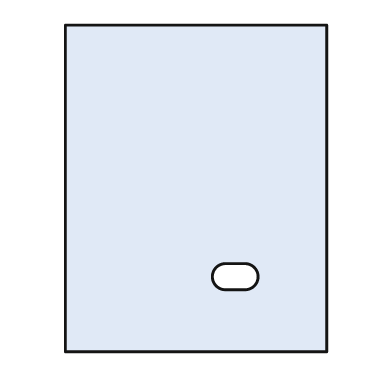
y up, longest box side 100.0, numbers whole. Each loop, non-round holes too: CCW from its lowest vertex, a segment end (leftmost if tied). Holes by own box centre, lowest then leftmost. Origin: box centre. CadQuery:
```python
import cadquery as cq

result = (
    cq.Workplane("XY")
    .moveTo(-40.0, -50.0)
    .lineTo(40.0, -50.0)
    .lineTo(40.0, 50.0)
    .lineTo(-40.0, 50.0)
    .close()
    .moveTo(9.0, -31.0)
    .lineTo(15.0, -31.0)
    .threePointArc((19.0, -27.0), (15.0, -23.0))
    .lineTo(9.0, -23.0)
    .threePointArc((5.0, -27.0), (9.0, -31.0))
    .close()
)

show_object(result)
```